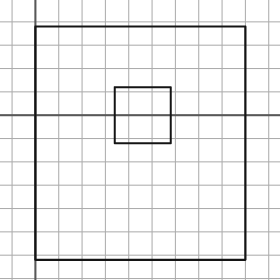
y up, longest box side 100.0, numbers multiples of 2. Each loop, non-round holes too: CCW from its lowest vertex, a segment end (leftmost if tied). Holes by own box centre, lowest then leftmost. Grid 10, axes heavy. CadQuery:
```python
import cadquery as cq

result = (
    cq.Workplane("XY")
    .moveTo(0.0, -62.0)
    .lineTo(90.0, -62.0)
    .lineTo(90.0, 38.0)
    .lineTo(0.0, 38.0)
    .close()
    .moveTo(34.0, -12.0)
    .lineTo(58.0, -12.0)
    .lineTo(58.0, 12.0)
    .lineTo(34.0, 12.0)
    .close()
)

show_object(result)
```